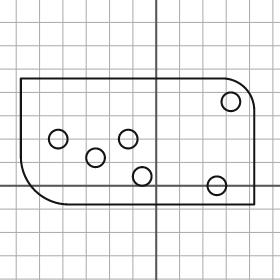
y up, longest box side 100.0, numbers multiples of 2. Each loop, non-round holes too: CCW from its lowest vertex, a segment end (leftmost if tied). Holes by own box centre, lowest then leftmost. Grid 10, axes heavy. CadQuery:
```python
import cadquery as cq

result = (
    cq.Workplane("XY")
    .moveTo(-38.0, -8.0)
    .lineTo(42.0, -8.0)
    .lineTo(42.0, 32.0)
    .threePointArc((38.0, 42.0), (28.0, 46.0))
    .lineTo(-58.0, 46.0)
    .lineTo(-58.0, 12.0)
    .threePointArc((-52.0, -2.0), (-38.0, -8.0))
    .close()
    .moveTo(26.0, 0.0)
    .circle(4.0)
    .moveTo(-6.0, 4.0)
    .circle(4.0)
    .moveTo(-26.0, 12.0)
    .circle(4.0)
    .moveTo(-42.0, 20.0)
    .circle(4.0)
    .moveTo(-12.0, 20.0)
    .circle(4.0)
    .moveTo(32.0, 36.0)
    .circle(4.0)
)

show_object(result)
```